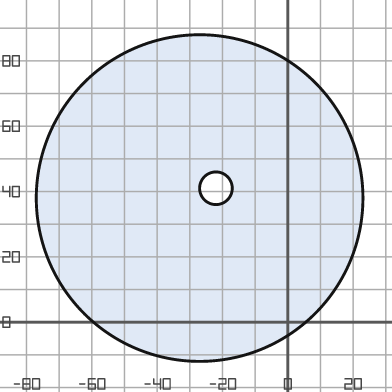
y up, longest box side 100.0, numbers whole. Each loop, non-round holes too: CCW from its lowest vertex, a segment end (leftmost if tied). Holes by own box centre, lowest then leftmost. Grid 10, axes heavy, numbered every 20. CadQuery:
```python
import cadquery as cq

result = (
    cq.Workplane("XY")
    .moveTo(-27.0, 38.0)
    .circle(50.0)
    .moveTo(-22.0, 41.0)
    .circle(5.0)
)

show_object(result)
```